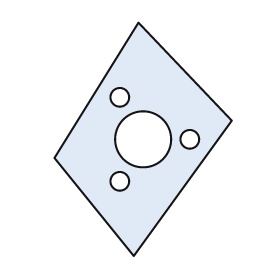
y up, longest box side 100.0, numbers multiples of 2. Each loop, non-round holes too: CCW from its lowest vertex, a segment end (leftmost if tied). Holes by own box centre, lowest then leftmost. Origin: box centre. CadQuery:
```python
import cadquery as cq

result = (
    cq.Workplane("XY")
    .moveTo(-4.0, -50.0)
    .lineTo(38.0, 8.0)
    .lineTo(-2.0, 50.0)
    .lineTo(-38.0, -8.0)
    .close()
    .moveTo(-10.0, -18.0)
    .circle(4.0)
    .moveTo(0.0, 0.0)
    .circle(12.0)
    .moveTo(20.0, 0.0)
    .circle(4.0)
    .moveTo(-10.0, 18.0)
    .circle(4.0)
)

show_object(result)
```